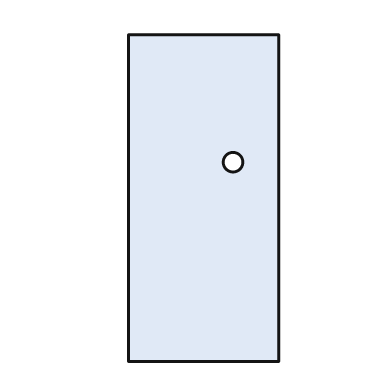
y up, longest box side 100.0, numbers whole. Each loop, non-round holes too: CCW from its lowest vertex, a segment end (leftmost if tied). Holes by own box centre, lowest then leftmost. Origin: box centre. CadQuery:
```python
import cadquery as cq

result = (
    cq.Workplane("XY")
    .moveTo(-23.0, -50.0)
    .lineTo(23.0, -50.0)
    .lineTo(23.0, 50.0)
    .lineTo(-23.0, 50.0)
    .close()
    .moveTo(9.0, 11.0)
    .circle(3.0)
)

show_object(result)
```